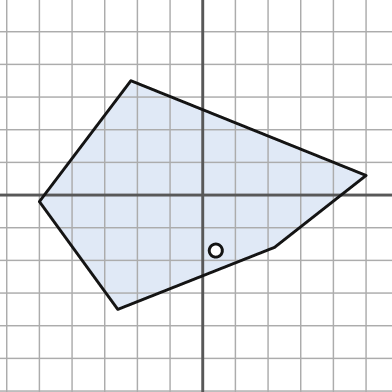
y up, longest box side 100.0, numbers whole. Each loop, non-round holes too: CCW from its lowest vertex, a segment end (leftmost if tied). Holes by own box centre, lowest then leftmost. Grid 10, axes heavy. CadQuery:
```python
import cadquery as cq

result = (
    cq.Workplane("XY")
    .moveTo(-26.0, -35.0)
    .lineTo(22.0, -16.0)
    .lineTo(50.0, 6.0)
    .lineTo(-22.0, 35.0)
    .lineTo(-50.0, -2.0)
    .close()
    .moveTo(4.0, -17.0)
    .circle(2.0)
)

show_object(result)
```